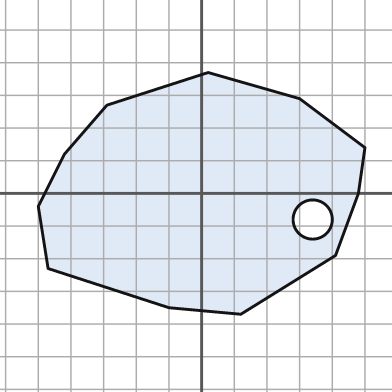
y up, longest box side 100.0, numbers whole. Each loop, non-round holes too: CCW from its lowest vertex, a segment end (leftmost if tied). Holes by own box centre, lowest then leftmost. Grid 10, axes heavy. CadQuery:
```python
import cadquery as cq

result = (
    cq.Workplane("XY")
    .moveTo(12.0, -37.0)
    .lineTo(41.0, -19.0)
    .lineTo(48.0, 0.0)
    .lineTo(50.0, 14.0)
    .lineTo(30.0, 29.0)
    .lineTo(2.0, 37.0)
    .lineTo(-29.0, 27.0)
    .lineTo(-42.0, 12.0)
    .lineTo(-50.0, -4.0)
    .lineTo(-47.0, -23.0)
    .lineTo(-10.0, -35.0)
    .close()
    .moveTo(34.0, -8.0)
    .circle(6.0)
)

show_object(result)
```